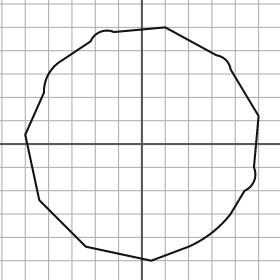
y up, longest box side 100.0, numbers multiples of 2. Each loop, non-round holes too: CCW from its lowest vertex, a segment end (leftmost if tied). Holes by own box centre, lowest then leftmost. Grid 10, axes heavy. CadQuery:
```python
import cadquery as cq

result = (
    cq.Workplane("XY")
    .moveTo(4.0, -50.0)
    .lineTo(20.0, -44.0)
    .threePointArc((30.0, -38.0), (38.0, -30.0))
    .lineTo(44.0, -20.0)
    .threePointArc((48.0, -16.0), (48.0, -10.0))
    .lineTo(50.0, 12.0)
    .lineTo(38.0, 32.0)
    .threePointArc((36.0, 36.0), (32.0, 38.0))
    .lineTo(10.0, 50.0)
    .lineTo(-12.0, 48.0)
    .threePointArc((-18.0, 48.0), (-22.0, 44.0))
    .lineTo(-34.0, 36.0)
    .threePointArc((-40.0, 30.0), (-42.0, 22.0))
    .lineTo(-50.0, 4.0)
    .lineTo(-44.0, -24.0)
    .lineTo(-24.0, -44.0)
    .close()
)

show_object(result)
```